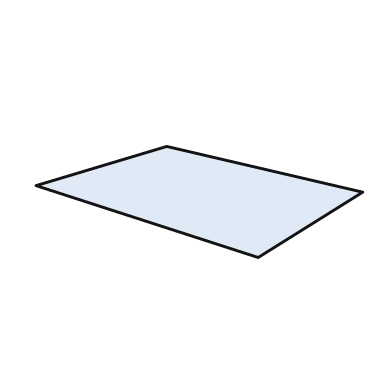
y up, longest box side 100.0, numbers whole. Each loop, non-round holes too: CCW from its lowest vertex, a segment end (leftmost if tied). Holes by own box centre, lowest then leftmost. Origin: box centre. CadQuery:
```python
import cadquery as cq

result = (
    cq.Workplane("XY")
    .moveTo(18.0, -17.0)
    .lineTo(50.0, 3.0)
    .lineTo(-10.0, 17.0)
    .lineTo(-50.0, 5.0)
    .close()
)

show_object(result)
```